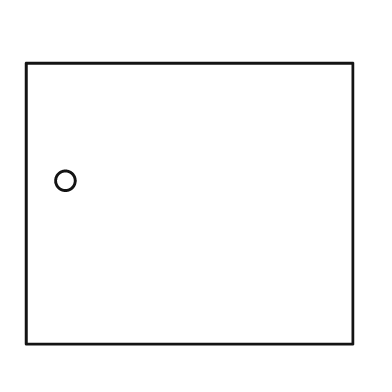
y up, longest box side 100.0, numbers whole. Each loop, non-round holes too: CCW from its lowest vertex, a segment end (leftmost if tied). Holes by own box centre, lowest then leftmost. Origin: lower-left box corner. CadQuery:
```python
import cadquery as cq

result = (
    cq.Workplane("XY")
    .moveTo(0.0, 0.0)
    .lineTo(100.0, 0.0)
    .lineTo(100.0, 86.0)
    .lineTo(0.0, 86.0)
    .close()
    .moveTo(12.0, 50.0)
    .circle(3.0)
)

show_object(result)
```